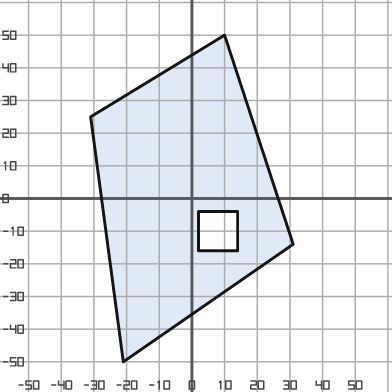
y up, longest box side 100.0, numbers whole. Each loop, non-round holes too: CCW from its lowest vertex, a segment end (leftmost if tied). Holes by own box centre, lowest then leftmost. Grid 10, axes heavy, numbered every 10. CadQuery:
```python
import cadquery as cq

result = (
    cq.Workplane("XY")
    .moveTo(-21.0, -50.0)
    .lineTo(31.0, -14.0)
    .lineTo(10.0, 50.0)
    .lineTo(-31.0, 25.0)
    .close()
    .moveTo(2.0, -16.0)
    .lineTo(14.0, -16.0)
    .lineTo(14.0, -4.0)
    .lineTo(2.0, -4.0)
    .close()
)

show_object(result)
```